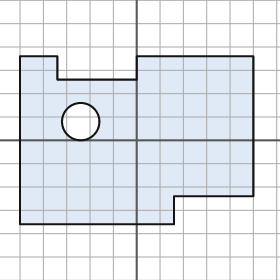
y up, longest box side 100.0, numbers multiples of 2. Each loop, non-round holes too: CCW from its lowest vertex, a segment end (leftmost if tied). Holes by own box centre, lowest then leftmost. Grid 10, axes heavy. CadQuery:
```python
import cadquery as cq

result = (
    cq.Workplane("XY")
    .moveTo(-50.0, -36.0)
    .lineTo(16.0, -36.0)
    .lineTo(16.0, -24.0)
    .lineTo(50.0, -24.0)
    .lineTo(50.0, 36.0)
    .lineTo(0.0, 36.0)
    .lineTo(0.0, 26.0)
    .lineTo(-34.0, 26.0)
    .lineTo(-34.0, 36.0)
    .lineTo(-50.0, 36.0)
    .close()
    .moveTo(-24.0, 8.0)
    .circle(8.0)
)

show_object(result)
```